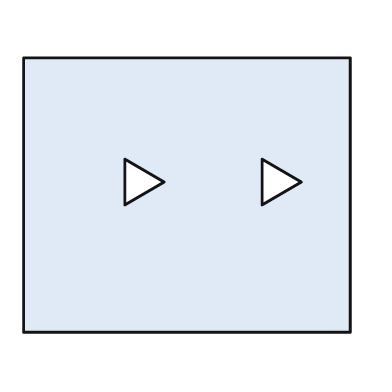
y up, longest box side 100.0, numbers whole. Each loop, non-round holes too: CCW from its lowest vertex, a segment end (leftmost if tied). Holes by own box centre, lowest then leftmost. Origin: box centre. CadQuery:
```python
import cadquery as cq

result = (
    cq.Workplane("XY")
    .moveTo(-50.0, -42.0)
    .lineTo(50.0, -42.0)
    .lineTo(50.0, 42.0)
    .lineTo(-50.0, 42.0)
    .close()
    .moveTo(-19.0, -3.0)
    .lineTo(-7.0, 4.0)
    .lineTo(-19.0, 11.0)
    .close()
    .moveTo(23.0, -3.0)
    .lineTo(35.0, 4.0)
    .lineTo(23.0, 11.0)
    .close()
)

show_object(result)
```